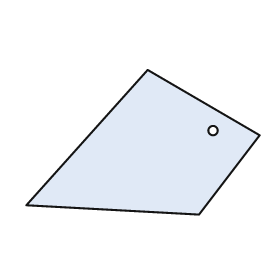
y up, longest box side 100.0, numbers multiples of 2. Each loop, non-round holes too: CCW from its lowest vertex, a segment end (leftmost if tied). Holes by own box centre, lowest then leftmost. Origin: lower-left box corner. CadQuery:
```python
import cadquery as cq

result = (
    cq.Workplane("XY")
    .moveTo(74.0, 0.0)
    .lineTo(100.0, 34.0)
    .lineTo(52.0, 62.0)
    .lineTo(0.0, 4.0)
    .close()
    .moveTo(80.0, 36.0)
    .circle(2.0)
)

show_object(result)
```